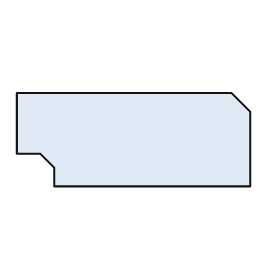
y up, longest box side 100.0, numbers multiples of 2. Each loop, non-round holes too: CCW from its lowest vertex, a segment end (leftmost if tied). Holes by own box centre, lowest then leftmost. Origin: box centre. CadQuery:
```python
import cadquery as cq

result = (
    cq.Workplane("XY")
    .moveTo(-34.0, -20.0)
    .lineTo(50.0, -20.0)
    .lineTo(50.0, 12.0)
    .lineTo(42.0, 20.0)
    .lineTo(-50.0, 20.0)
    .lineTo(-50.0, -6.0)
    .lineTo(-40.0, -6.0)
    .lineTo(-34.0, -12.0)
    .close()
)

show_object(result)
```